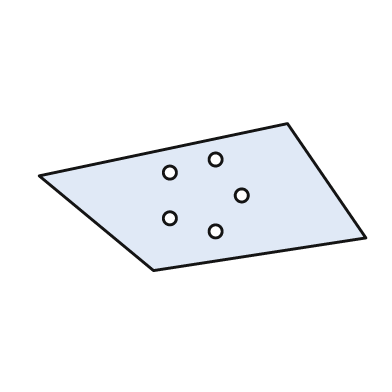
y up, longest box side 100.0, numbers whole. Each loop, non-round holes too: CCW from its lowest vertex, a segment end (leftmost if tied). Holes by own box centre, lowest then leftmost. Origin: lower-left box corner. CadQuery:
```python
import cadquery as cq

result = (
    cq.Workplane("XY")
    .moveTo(35.0, 0.0)
    .lineTo(100.0, 10.0)
    .lineTo(76.0, 45.0)
    .lineTo(0.0, 29.0)
    .close()
    .moveTo(54.0, 12.0)
    .circle(2.0)
    .moveTo(40.0, 16.0)
    .circle(2.0)
    .moveTo(62.0, 23.0)
    .circle(2.0)
    .moveTo(40.0, 30.0)
    .circle(2.0)
    .moveTo(54.0, 34.0)
    .circle(2.0)
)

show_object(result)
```